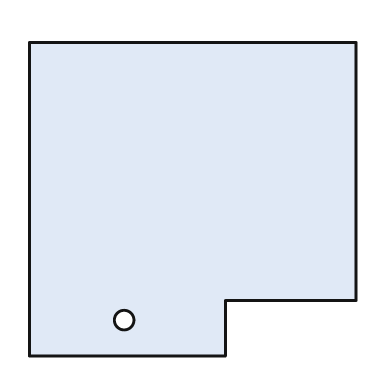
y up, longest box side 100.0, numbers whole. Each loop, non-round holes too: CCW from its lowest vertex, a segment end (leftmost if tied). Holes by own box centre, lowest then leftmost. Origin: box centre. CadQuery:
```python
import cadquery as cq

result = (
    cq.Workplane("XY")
    .moveTo(-50.0, -48.0)
    .lineTo(10.0, -48.0)
    .lineTo(10.0, -31.0)
    .lineTo(50.0, -31.0)
    .lineTo(50.0, 48.0)
    .lineTo(-50.0, 48.0)
    .close()
    .moveTo(-21.0, -37.0)
    .circle(3.0)
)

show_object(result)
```